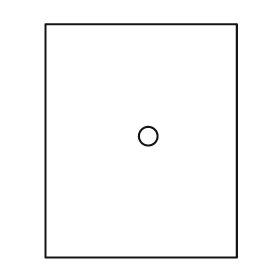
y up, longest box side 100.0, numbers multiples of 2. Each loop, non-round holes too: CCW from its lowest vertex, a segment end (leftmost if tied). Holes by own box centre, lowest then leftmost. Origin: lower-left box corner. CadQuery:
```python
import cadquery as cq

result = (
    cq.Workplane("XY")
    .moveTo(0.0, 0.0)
    .lineTo(82.0, 0.0)
    .lineTo(82.0, 100.0)
    .lineTo(0.0, 100.0)
    .close()
    .moveTo(44.0, 52.0)
    .circle(4.0)
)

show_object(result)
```